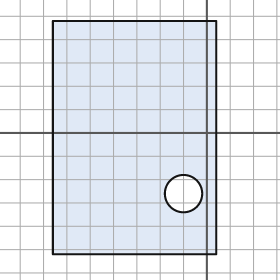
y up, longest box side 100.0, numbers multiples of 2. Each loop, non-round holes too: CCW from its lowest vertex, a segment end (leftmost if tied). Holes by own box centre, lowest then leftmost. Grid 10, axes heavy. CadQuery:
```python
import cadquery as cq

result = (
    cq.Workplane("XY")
    .moveTo(-66.0, -52.0)
    .lineTo(4.0, -52.0)
    .lineTo(4.0, 48.0)
    .lineTo(-66.0, 48.0)
    .close()
    .moveTo(-10.0, -26.0)
    .circle(8.0)
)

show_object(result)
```